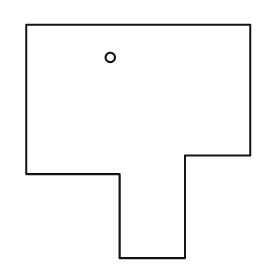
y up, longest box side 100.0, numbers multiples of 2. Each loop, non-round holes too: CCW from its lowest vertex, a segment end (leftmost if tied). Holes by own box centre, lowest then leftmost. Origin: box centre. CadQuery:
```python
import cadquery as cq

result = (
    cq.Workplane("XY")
    .moveTo(-8.0, -50.0)
    .lineTo(20.0, -50.0)
    .lineTo(20.0, -6.0)
    .lineTo(48.0, -6.0)
    .lineTo(48.0, 50.0)
    .lineTo(-48.0, 50.0)
    .lineTo(-48.0, -14.0)
    .lineTo(-8.0, -14.0)
    .close()
    .moveTo(-12.0, 36.0)
    .circle(2.0)
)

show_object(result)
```